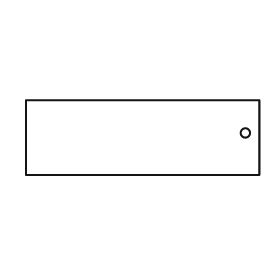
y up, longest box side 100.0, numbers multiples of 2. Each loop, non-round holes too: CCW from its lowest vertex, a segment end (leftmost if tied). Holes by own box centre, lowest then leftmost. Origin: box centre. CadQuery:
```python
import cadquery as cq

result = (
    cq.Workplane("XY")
    .moveTo(-50.0, -16.0)
    .lineTo(50.0, -16.0)
    .lineTo(50.0, 16.0)
    .lineTo(-50.0, 16.0)
    .close()
    .moveTo(44.0, 2.0)
    .circle(2.0)
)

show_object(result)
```